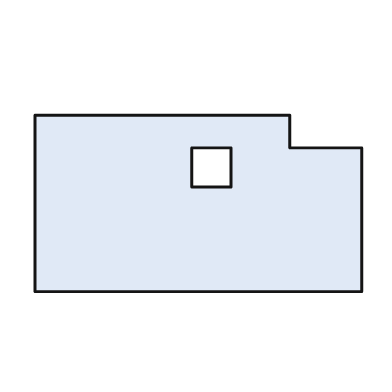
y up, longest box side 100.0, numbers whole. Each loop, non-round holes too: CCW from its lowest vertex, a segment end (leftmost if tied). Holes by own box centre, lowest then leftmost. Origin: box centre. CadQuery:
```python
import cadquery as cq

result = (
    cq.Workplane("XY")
    .moveTo(-50.0, -27.0)
    .lineTo(50.0, -27.0)
    .lineTo(50.0, 17.0)
    .lineTo(28.0, 17.0)
    .lineTo(28.0, 27.0)
    .lineTo(-50.0, 27.0)
    .close()
    .moveTo(-2.0, 5.0)
    .lineTo(10.0, 5.0)
    .lineTo(10.0, 17.0)
    .lineTo(-2.0, 17.0)
    .close()
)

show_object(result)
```